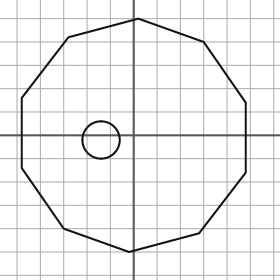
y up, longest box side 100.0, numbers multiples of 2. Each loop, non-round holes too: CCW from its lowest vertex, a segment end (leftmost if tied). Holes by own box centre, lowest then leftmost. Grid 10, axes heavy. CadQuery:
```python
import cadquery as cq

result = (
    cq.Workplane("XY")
    .moveTo(-2.0, -50.0)
    .lineTo(28.0, -42.0)
    .lineTo(48.0, -16.0)
    .lineTo(48.0, 14.0)
    .lineTo(30.0, 40.0)
    .lineTo(2.0, 50.0)
    .lineTo(-28.0, 42.0)
    .lineTo(-48.0, 16.0)
    .lineTo(-48.0, -14.0)
    .lineTo(-30.0, -40.0)
    .close()
    .moveTo(-14.0, -2.0)
    .circle(8.0)
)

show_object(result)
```